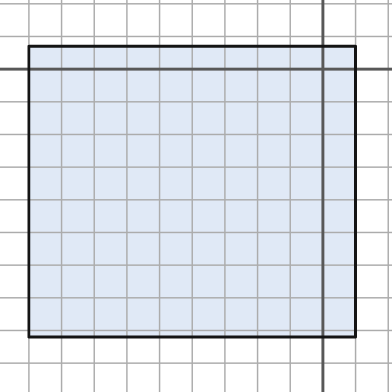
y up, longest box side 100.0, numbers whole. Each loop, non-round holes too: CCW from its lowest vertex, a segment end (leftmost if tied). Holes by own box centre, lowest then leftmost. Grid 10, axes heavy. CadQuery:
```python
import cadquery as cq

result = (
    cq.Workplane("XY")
    .moveTo(-90.0, -82.0)
    .lineTo(10.0, -82.0)
    .lineTo(10.0, 7.0)
    .lineTo(-90.0, 7.0)
    .close()
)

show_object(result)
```